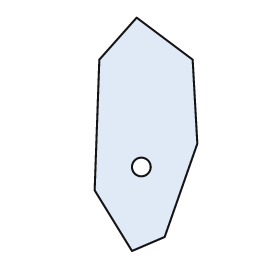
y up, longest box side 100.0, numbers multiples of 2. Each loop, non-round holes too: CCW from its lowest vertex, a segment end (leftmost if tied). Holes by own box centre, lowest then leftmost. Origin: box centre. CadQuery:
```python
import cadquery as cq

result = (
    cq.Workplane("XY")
    .moveTo(-6.0, -50.0)
    .lineTo(8.0, -44.0)
    .lineTo(22.0, -4.0)
    .lineTo(20.0, 32.0)
    .lineTo(-4.0, 50.0)
    .lineTo(-20.0, 32.0)
    .lineTo(-22.0, -24.0)
    .close()
    .moveTo(-2.0, -14.0)
    .circle(4.0)
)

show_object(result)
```